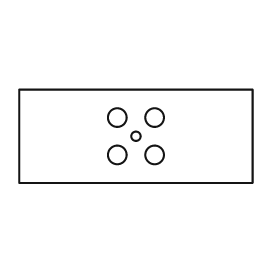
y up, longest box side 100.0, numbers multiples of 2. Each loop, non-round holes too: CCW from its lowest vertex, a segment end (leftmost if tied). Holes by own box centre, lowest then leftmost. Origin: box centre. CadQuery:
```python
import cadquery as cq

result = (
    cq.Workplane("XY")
    .moveTo(-50.0, -20.0)
    .lineTo(50.0, -20.0)
    .lineTo(50.0, 20.0)
    .lineTo(-50.0, 20.0)
    .close()
    .moveTo(-8.0, -8.0)
    .circle(4.0)
    .moveTo(8.0, -8.0)
    .circle(4.0)
    .moveTo(0.0, 0.0)
    .circle(2.0)
    .moveTo(-8.0, 8.0)
    .circle(4.0)
    .moveTo(8.0, 8.0)
    .circle(4.0)
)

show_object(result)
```